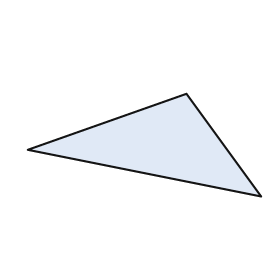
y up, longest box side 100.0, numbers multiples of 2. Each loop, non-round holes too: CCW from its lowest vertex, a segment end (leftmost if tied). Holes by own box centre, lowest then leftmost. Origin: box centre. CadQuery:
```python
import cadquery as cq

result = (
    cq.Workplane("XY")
    .moveTo(50.0, -22.0)
    .lineTo(18.0, 22.0)
    .lineTo(-50.0, -2.0)
    .close()
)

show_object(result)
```